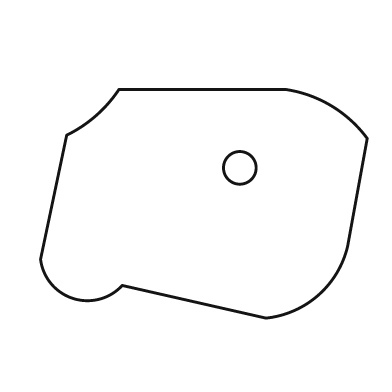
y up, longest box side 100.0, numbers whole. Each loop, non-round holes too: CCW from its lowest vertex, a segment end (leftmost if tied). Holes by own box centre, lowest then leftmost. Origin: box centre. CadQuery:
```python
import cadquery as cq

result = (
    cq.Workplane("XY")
    .moveTo(19.0, -35.0)
    .threePointArc((35.0, -28.0), (44.0, -13.0))
    .lineTo(50.0, 20.0)
    .threePointArc((39.0, 30.0), (25.0, 35.0))
    .lineTo(-26.0, 35.0)
    .threePointArc((-33.0, 27.0), (-42.0, 21.0))
    .lineTo(-50.0, -17.0)
    .threePointArc((-40.0, -29.0), (-25.0, -25.0))
    .close()
    .moveTo(11.0, 11.0)
    .circle(5.0)
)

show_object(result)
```